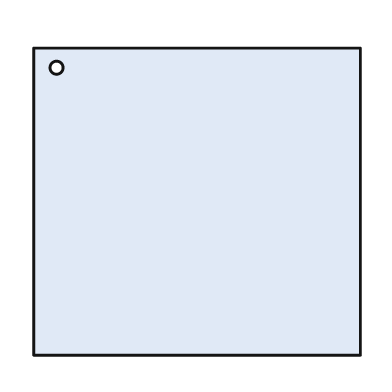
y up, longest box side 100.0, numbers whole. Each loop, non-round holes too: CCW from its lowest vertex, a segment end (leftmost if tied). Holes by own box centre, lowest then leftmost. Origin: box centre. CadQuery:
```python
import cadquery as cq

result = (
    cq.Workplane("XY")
    .moveTo(-50.0, -47.0)
    .lineTo(50.0, -47.0)
    .lineTo(50.0, 47.0)
    .lineTo(-50.0, 47.0)
    .close()
    .moveTo(-43.0, 41.0)
    .circle(2.0)
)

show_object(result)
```